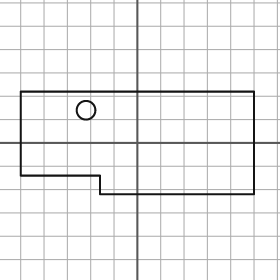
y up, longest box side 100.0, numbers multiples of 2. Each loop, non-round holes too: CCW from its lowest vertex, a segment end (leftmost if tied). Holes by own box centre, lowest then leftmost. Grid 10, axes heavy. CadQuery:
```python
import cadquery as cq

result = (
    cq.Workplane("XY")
    .moveTo(-16.0, -22.0)
    .lineTo(50.0, -22.0)
    .lineTo(50.0, 22.0)
    .lineTo(-50.0, 22.0)
    .lineTo(-50.0, -14.0)
    .lineTo(-16.0, -14.0)
    .close()
    .moveTo(-22.0, 14.0)
    .circle(4.0)
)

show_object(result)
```